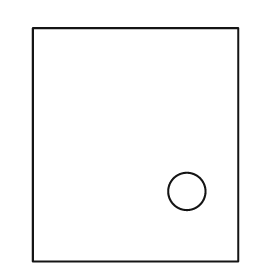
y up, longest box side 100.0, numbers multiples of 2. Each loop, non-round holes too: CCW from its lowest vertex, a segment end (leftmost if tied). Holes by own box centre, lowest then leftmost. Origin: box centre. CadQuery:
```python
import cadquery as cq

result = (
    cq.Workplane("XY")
    .moveTo(-44.0, -50.0)
    .lineTo(44.0, -50.0)
    .lineTo(44.0, 50.0)
    .lineTo(-44.0, 50.0)
    .close()
    .moveTo(22.0, -20.0)
    .circle(8.0)
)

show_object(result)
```